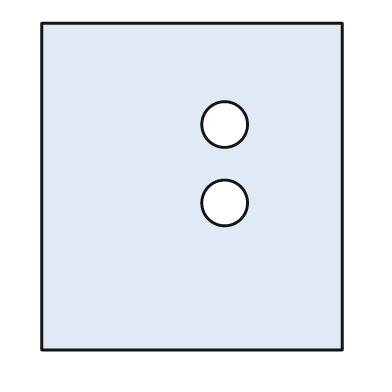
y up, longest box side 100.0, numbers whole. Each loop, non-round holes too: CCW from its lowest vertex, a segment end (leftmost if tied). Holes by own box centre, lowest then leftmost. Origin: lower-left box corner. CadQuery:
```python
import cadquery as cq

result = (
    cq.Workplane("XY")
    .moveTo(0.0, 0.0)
    .lineTo(92.0, 0.0)
    .lineTo(92.0, 100.0)
    .lineTo(0.0, 100.0)
    .close()
    .moveTo(56.0, 45.0)
    .circle(7.0)
    .moveTo(56.0, 69.0)
    .circle(7.0)
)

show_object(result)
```